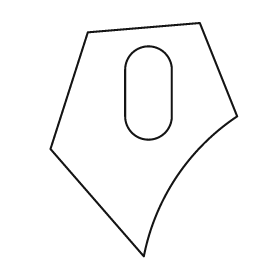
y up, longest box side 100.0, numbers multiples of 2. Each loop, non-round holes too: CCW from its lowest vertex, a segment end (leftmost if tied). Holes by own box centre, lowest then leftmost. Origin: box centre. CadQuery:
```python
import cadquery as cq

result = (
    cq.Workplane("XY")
    .moveTo(0.0, -50.0)
    .threePointArc((14.0, -16.0), (40.0, 10.0))
    .lineTo(24.0, 50.0)
    .lineTo(-24.0, 46.0)
    .lineTo(-40.0, -4.0)
    .close()
    .moveTo(-8.0, 10.0)
    .threePointArc((2.0, 0.0), (12.0, 10.0))
    .lineTo(12.0, 30.0)
    .threePointArc((2.0, 40.0), (-8.0, 30.0))
    .close()
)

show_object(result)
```